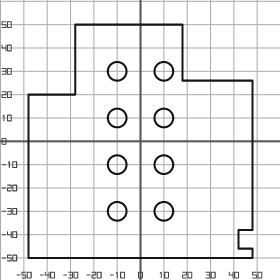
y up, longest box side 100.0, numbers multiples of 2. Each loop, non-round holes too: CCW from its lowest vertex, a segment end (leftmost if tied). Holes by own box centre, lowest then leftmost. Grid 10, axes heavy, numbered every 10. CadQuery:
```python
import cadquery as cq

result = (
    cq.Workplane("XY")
    .moveTo(-48.0, -50.0)
    .lineTo(48.0, -50.0)
    .lineTo(48.0, -46.0)
    .lineTo(42.0, -46.0)
    .lineTo(42.0, -38.0)
    .lineTo(48.0, -38.0)
    .lineTo(48.0, 26.0)
    .lineTo(18.0, 26.0)
    .lineTo(18.0, 50.0)
    .lineTo(-28.0, 50.0)
    .lineTo(-28.0, 20.0)
    .lineTo(-48.0, 20.0)
    .close()
    .moveTo(-10.0, -30.0)
    .circle(4.0)
    .moveTo(10.0, -30.0)
    .circle(4.0)
    .moveTo(-10.0, -10.0)
    .circle(4.0)
    .moveTo(10.0, -10.0)
    .circle(4.0)
    .moveTo(-10.0, 10.0)
    .circle(4.0)
    .moveTo(10.0, 10.0)
    .circle(4.0)
    .moveTo(-10.0, 30.0)
    .circle(4.0)
    .moveTo(10.0, 30.0)
    .circle(4.0)
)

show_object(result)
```